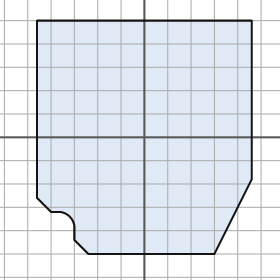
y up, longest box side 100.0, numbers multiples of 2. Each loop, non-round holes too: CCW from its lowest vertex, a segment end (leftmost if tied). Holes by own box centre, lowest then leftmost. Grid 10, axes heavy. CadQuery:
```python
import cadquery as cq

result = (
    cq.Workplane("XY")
    .moveTo(-24.0, -50.0)
    .lineTo(30.0, -50.0)
    .lineTo(46.0, -18.0)
    .lineTo(46.0, 50.0)
    .lineTo(-46.0, 50.0)
    .lineTo(-46.0, -26.0)
    .lineTo(-40.0, -32.0)
    .lineTo(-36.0, -32.0)
    .threePointArc((-32.0, -34.0), (-30.0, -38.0))
    .lineTo(-30.0, -44.0)
    .close()
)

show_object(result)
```